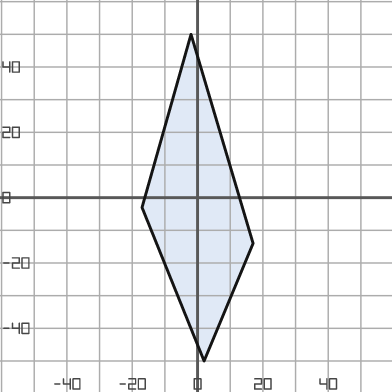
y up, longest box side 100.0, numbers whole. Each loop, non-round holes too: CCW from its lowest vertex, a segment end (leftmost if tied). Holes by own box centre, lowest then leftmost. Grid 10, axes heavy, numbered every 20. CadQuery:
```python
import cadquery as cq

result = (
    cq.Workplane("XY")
    .moveTo(2.0, -50.0)
    .lineTo(17.0, -14.0)
    .lineTo(-2.0, 50.0)
    .lineTo(-17.0, -3.0)
    .close()
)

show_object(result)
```